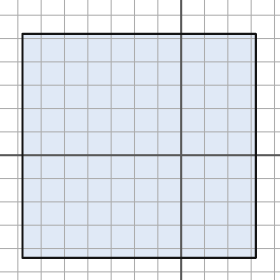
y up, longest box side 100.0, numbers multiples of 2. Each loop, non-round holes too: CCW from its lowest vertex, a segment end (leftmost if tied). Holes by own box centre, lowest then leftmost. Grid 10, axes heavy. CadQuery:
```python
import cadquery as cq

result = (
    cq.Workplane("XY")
    .moveTo(-68.0, -44.0)
    .lineTo(32.0, -44.0)
    .lineTo(32.0, 52.0)
    .lineTo(-68.0, 52.0)
    .close()
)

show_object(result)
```